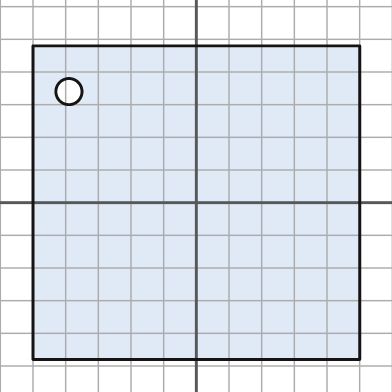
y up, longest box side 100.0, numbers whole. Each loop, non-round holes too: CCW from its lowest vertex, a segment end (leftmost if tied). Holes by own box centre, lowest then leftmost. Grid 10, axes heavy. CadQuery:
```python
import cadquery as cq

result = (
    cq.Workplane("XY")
    .moveTo(-50.0, -48.0)
    .lineTo(50.0, -48.0)
    .lineTo(50.0, 48.0)
    .lineTo(-50.0, 48.0)
    .close()
    .moveTo(-39.0, 34.0)
    .circle(4.0)
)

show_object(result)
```